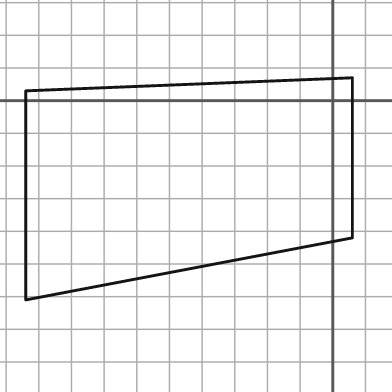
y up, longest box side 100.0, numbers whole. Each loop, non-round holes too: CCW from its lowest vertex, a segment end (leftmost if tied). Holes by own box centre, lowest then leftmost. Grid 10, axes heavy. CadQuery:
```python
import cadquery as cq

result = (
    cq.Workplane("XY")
    .moveTo(-94.0, -61.0)
    .lineTo(6.0, -42.0)
    .lineTo(6.0, 7.0)
    .lineTo(-94.0, 3.0)
    .close()
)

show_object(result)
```